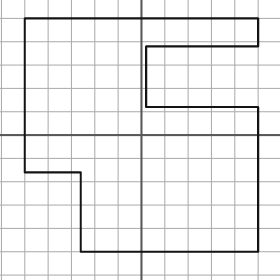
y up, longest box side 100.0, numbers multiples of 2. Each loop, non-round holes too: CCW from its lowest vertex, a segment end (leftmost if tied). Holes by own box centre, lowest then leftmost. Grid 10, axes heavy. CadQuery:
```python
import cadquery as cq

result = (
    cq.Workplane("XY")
    .moveTo(-26.0, -50.0)
    .lineTo(50.0, -50.0)
    .lineTo(50.0, 12.0)
    .lineTo(2.0, 12.0)
    .lineTo(2.0, 38.0)
    .lineTo(50.0, 38.0)
    .lineTo(50.0, 50.0)
    .lineTo(-50.0, 50.0)
    .lineTo(-50.0, -16.0)
    .lineTo(-26.0, -16.0)
    .close()
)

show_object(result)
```